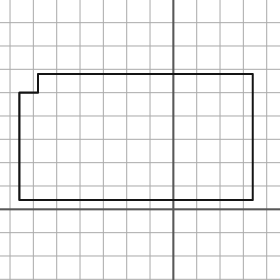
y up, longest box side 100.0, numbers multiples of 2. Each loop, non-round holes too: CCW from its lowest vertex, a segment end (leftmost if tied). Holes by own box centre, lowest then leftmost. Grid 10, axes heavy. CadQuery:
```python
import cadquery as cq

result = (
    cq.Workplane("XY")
    .moveTo(-66.0, 4.0)
    .lineTo(34.0, 4.0)
    .lineTo(34.0, 58.0)
    .lineTo(-58.0, 58.0)
    .lineTo(-58.0, 50.0)
    .lineTo(-66.0, 50.0)
    .close()
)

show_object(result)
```